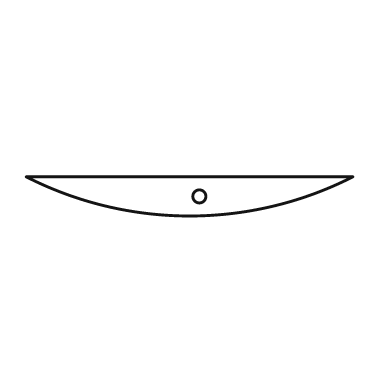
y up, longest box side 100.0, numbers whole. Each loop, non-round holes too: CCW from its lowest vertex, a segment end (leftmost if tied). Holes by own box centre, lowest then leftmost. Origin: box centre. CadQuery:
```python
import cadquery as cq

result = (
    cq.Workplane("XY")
    .moveTo(-50.0, 6.0)
    .threePointArc((0.0, -6.0), (50.0, 6.0))
    .close()
    .moveTo(3.0, 0.0)
    .circle(2.0)
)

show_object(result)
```